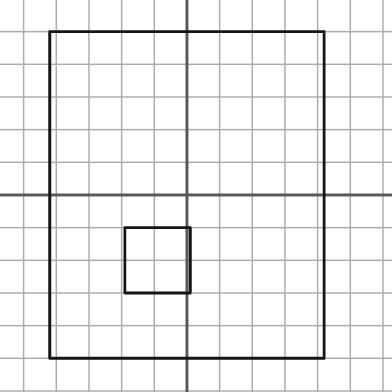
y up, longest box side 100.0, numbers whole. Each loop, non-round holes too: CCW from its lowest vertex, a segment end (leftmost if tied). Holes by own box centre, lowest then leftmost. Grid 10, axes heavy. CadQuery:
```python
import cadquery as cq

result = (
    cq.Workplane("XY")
    .moveTo(-42.0, -50.0)
    .lineTo(42.0, -50.0)
    .lineTo(42.0, 50.0)
    .lineTo(-42.0, 50.0)
    .close()
    .moveTo(-19.0, -30.0)
    .lineTo(1.0, -30.0)
    .lineTo(1.0, -10.0)
    .lineTo(-19.0, -10.0)
    .close()
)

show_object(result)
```